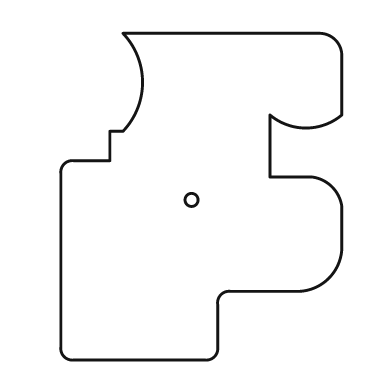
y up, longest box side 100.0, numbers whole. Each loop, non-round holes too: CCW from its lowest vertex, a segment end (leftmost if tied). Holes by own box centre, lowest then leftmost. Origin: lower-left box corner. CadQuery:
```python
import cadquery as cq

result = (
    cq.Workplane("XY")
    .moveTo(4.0, 0.0)
    .lineTo(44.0, 0.0)
    .threePointArc((47.0, 1.0), (48.0, 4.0))
    .lineTo(48.0, 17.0)
    .threePointArc((49.0, 20.0), (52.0, 21.0))
    .lineTo(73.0, 21.0)
    .threePointArc((82.0, 25.0), (86.0, 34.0))
    .lineTo(86.0, 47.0)
    .threePointArc((83.0, 53.0), (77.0, 56.0))
    .lineTo(64.0, 56.0)
    .lineTo(64.0, 75.0)
    .threePointArc((75.0, 71.0), (86.0, 75.0))
    .lineTo(86.0, 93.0)
    .threePointArc((84.0, 98.0), (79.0, 100.0))
    .lineTo(19.0, 100.0)
    .threePointArc((25.0, 85.0), (19.0, 70.0))
    .lineTo(15.0, 70.0)
    .lineTo(15.0, 61.0)
    .lineTo(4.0, 61.0)
    .threePointArc((1.0, 60.0), (0.0, 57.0))
    .lineTo(0.0, 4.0)
    .threePointArc((1.0, 1.0), (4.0, 0.0))
    .close()
    .moveTo(40.0, 49.0)
    .circle(2.0)
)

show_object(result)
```